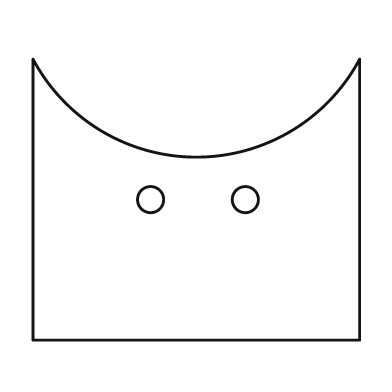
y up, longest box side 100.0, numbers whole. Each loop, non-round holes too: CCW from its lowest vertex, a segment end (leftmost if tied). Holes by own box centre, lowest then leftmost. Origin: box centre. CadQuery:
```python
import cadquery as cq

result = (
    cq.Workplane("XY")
    .moveTo(-50.0, -43.0)
    .lineTo(50.0, -43.0)
    .lineTo(50.0, 43.0)
    .threePointArc((0.0, 13.0), (-50.0, 43.0))
    .close()
    .moveTo(-14.0, 0.0)
    .circle(4.0)
    .moveTo(15.0, 0.0)
    .circle(4.0)
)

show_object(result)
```